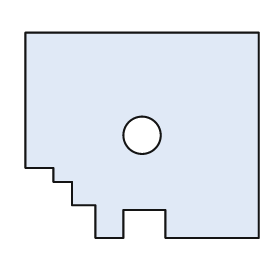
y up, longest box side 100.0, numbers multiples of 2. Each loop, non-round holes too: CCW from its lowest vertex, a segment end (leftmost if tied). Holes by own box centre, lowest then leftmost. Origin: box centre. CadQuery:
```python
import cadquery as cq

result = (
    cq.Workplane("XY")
    .moveTo(-20.0, -44.0)
    .lineTo(-8.0, -44.0)
    .lineTo(-8.0, -32.0)
    .lineTo(10.0, -32.0)
    .lineTo(10.0, -44.0)
    .lineTo(50.0, -44.0)
    .lineTo(50.0, 44.0)
    .lineTo(-50.0, 44.0)
    .lineTo(-50.0, -14.0)
    .lineTo(-38.0, -14.0)
    .lineTo(-38.0, -20.0)
    .lineTo(-30.0, -20.0)
    .lineTo(-30.0, -30.0)
    .lineTo(-20.0, -30.0)
    .close()
    .moveTo(0.0, 0.0)
    .circle(8.0)
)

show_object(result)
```